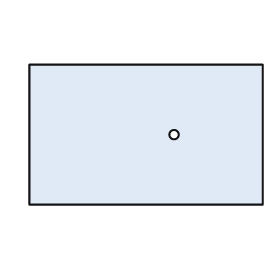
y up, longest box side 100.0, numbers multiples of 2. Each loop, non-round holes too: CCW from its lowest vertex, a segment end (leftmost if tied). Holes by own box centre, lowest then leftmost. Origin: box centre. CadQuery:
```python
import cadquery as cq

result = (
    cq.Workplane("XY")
    .moveTo(-50.0, -30.0)
    .lineTo(50.0, -30.0)
    .lineTo(50.0, 30.0)
    .lineTo(-50.0, 30.0)
    .close()
    .moveTo(12.0, 0.0)
    .circle(2.0)
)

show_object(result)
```